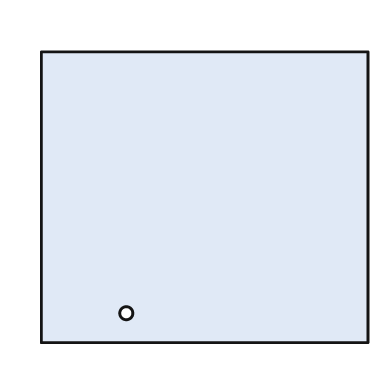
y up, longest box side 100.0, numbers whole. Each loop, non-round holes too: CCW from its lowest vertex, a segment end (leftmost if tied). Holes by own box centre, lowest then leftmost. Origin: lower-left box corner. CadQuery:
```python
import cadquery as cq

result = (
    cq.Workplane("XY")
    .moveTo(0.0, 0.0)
    .lineTo(100.0, 0.0)
    .lineTo(100.0, 89.0)
    .lineTo(0.0, 89.0)
    .close()
    .moveTo(26.0, 9.0)
    .circle(2.0)
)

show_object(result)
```